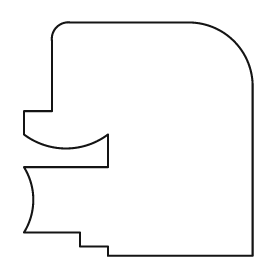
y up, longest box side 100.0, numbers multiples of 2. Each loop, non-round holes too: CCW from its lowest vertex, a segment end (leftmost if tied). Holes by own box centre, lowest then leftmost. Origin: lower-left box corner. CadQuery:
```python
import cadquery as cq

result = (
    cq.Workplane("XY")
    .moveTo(36.0, 0.0)
    .lineTo(98.0, 0.0)
    .lineTo(98.0, 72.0)
    .threePointArc((90.0, 92.0), (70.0, 100.0))
    .lineTo(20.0, 100.0)
    .threePointArc((14.0, 98.0), (12.0, 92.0))
    .lineTo(12.0, 62.0)
    .lineTo(0.0, 62.0)
    .lineTo(0.0, 52.0)
    .threePointArc((18.0, 46.0), (36.0, 52.0))
    .lineTo(36.0, 38.0)
    .lineTo(0.0, 38.0)
    .threePointArc((4.0, 24.0), (0.0, 10.0))
    .lineTo(24.0, 10.0)
    .lineTo(24.0, 4.0)
    .lineTo(36.0, 4.0)
    .close()
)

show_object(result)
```